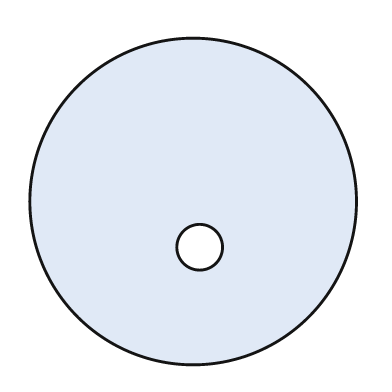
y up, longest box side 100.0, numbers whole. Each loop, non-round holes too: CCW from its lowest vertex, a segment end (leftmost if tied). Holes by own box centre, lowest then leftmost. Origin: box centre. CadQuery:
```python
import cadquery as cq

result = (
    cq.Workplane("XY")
    .moveTo(0.0, 0.0)
    .circle(50.0)
    .moveTo(2.0, -14.0)
    .circle(7.0)
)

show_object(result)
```